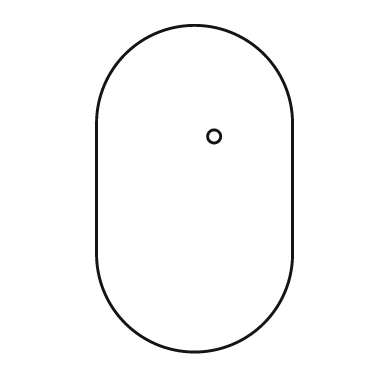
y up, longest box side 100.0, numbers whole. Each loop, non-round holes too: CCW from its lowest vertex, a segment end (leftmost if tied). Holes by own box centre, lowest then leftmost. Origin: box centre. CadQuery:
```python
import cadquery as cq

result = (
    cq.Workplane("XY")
    .moveTo(-30.0, -20.0)
    .threePointArc((0.0, -50.0), (30.0, -20.0))
    .lineTo(30.0, 20.0)
    .threePointArc((0.0, 50.0), (-30.0, 20.0))
    .close()
    .moveTo(6.0, 16.0)
    .circle(2.0)
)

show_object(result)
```